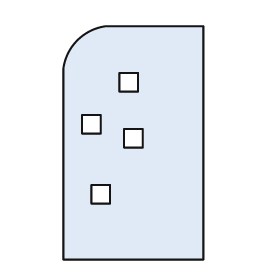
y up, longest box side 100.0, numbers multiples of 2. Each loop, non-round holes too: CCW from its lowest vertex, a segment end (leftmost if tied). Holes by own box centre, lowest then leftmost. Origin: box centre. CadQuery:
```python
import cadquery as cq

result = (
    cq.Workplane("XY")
    .moveTo(-30.0, -50.0)
    .lineTo(30.0, -50.0)
    .lineTo(30.0, 50.0)
    .lineTo(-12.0, 50.0)
    .threePointArc((-24.0, 44.0), (-30.0, 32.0))
    .close()
    .moveTo(-18.0, -26.0)
    .lineTo(-10.0, -26.0)
    .lineTo(-10.0, -18.0)
    .lineTo(-18.0, -18.0)
    .close()
    .moveTo(-4.0, -2.0)
    .lineTo(4.0, -2.0)
    .lineTo(4.0, 6.0)
    .lineTo(-4.0, 6.0)
    .close()
    .moveTo(-22.0, 4.0)
    .lineTo(-14.0, 4.0)
    .lineTo(-14.0, 12.0)
    .lineTo(-22.0, 12.0)
    .close()
    .moveTo(-6.0, 22.0)
    .lineTo(2.0, 22.0)
    .lineTo(2.0, 30.0)
    .lineTo(-6.0, 30.0)
    .close()
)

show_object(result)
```